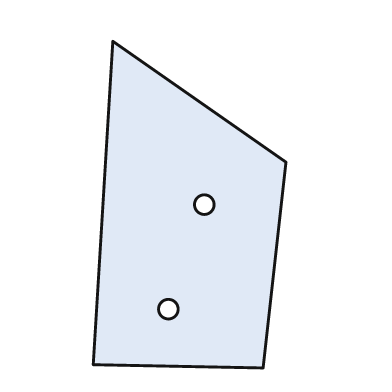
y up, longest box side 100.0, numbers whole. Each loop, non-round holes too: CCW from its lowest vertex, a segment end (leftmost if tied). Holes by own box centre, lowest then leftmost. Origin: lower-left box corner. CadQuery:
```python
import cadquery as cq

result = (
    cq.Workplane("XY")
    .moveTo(52.0, 0.0)
    .lineTo(59.0, 63.0)
    .lineTo(6.0, 100.0)
    .lineTo(0.0, 1.0)
    .close()
    .moveTo(23.0, 18.0)
    .circle(3.0)
    .moveTo(34.0, 50.0)
    .circle(3.0)
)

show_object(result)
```